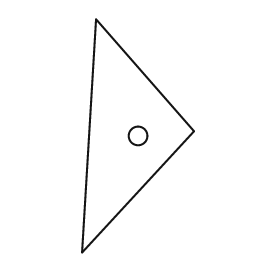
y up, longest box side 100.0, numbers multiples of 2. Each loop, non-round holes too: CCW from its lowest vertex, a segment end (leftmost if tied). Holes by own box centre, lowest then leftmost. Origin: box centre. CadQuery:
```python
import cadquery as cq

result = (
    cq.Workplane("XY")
    .moveTo(-24.0, -50.0)
    .lineTo(24.0, 2.0)
    .lineTo(-18.0, 50.0)
    .close()
    .moveTo(0.0, 0.0)
    .circle(4.0)
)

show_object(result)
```